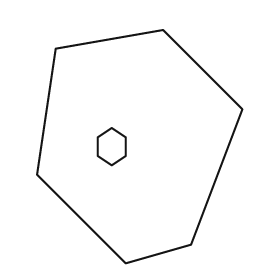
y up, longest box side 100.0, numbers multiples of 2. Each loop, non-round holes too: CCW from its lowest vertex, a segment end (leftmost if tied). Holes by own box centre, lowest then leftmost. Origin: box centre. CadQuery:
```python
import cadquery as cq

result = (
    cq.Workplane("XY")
    .moveTo(-6.0, -50.0)
    .lineTo(22.0, -42.0)
    .lineTo(44.0, 16.0)
    .lineTo(10.0, 50.0)
    .lineTo(-36.0, 42.0)
    .lineTo(-44.0, -12.0)
    .close()
    .moveTo(-12.0, -8.0)
    .lineTo(-6.0, -4.0)
    .lineTo(-6.0, 4.0)
    .lineTo(-12.0, 8.0)
    .lineTo(-18.0, 4.0)
    .lineTo(-18.0, -4.0)
    .close()
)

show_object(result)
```